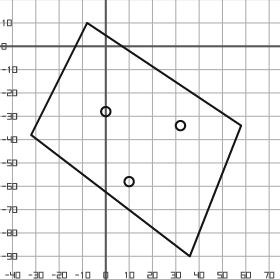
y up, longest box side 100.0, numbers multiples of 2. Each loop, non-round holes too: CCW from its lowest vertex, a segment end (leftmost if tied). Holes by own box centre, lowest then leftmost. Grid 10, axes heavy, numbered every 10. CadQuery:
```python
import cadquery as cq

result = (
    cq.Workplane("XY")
    .moveTo(36.0, -90.0)
    .lineTo(58.0, -34.0)
    .lineTo(-8.0, 10.0)
    .lineTo(-32.0, -38.0)
    .close()
    .moveTo(10.0, -58.0)
    .circle(2.0)
    .moveTo(32.0, -34.0)
    .circle(2.0)
    .moveTo(0.0, -28.0)
    .circle(2.0)
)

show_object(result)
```